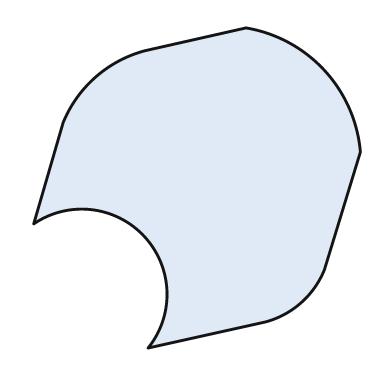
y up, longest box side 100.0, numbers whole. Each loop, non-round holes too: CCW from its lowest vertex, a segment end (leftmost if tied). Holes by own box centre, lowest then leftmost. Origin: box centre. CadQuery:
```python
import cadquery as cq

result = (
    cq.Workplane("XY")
    .moveTo(-15.0, -49.0)
    .lineTo(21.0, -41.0)
    .threePointArc((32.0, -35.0), (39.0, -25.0))
    .lineTo(50.0, 11.0)
    .threePointArc((39.0, 36.0), (15.0, 49.0))
    .lineTo(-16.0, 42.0)
    .threePointArc((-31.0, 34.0), (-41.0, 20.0))
    .lineTo(-50.0, -11.0)
    .threePointArc((-16.0, -15.0), (-15.0, -49.0))
    .close()
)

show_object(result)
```